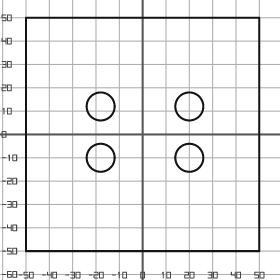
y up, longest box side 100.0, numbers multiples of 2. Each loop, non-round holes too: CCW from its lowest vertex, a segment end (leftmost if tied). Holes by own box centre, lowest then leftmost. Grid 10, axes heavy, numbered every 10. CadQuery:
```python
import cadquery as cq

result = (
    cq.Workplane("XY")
    .moveTo(-50.0, -50.0)
    .lineTo(50.0, -50.0)
    .lineTo(50.0, 50.0)
    .lineTo(-50.0, 50.0)
    .close()
    .moveTo(-18.0, -10.0)
    .circle(6.0)
    .moveTo(20.0, -10.0)
    .circle(6.0)
    .moveTo(-18.0, 12.0)
    .circle(6.0)
    .moveTo(20.0, 12.0)
    .circle(6.0)
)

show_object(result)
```